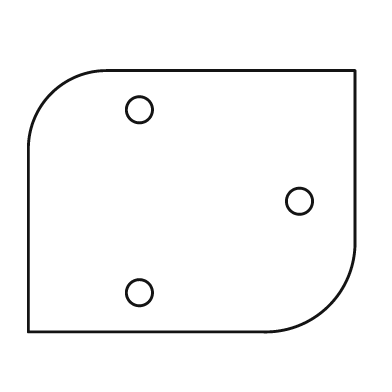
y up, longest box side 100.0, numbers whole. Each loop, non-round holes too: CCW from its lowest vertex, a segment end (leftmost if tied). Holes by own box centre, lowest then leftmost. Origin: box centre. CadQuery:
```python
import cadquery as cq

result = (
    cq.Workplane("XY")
    .moveTo(-50.0, -40.0)
    .lineTo(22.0, -40.0)
    .threePointArc((42.0, -32.0), (50.0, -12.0))
    .lineTo(50.0, 40.0)
    .lineTo(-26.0, 40.0)
    .threePointArc((-43.0, 33.0), (-50.0, 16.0))
    .close()
    .moveTo(-16.0, -28.0)
    .circle(4.0)
    .moveTo(33.0, 0.0)
    .circle(4.0)
    .moveTo(-16.0, 28.0)
    .circle(4.0)
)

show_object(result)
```